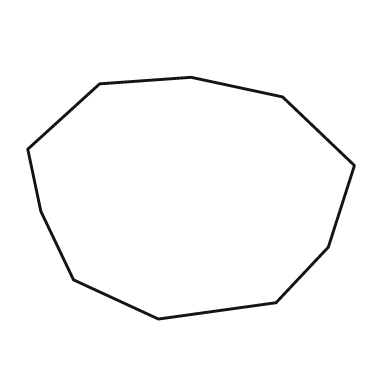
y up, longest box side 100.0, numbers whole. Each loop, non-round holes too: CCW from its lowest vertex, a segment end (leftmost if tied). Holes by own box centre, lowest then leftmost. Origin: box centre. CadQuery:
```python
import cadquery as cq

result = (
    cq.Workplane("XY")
    .moveTo(-10.0, -37.0)
    .lineTo(26.0, -32.0)
    .lineTo(42.0, -15.0)
    .lineTo(50.0, 10.0)
    .lineTo(28.0, 31.0)
    .lineTo(0.0, 37.0)
    .lineTo(-28.0, 35.0)
    .lineTo(-50.0, 15.0)
    .lineTo(-46.0, -4.0)
    .lineTo(-36.0, -25.0)
    .close()
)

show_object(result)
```